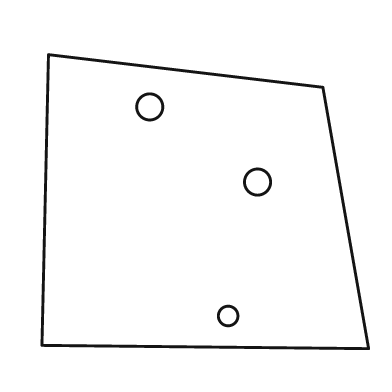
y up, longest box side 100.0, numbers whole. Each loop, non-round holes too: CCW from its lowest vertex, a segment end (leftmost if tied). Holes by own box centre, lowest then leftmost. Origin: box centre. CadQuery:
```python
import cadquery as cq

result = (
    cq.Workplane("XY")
    .moveTo(50.0, -45.0)
    .lineTo(36.0, 35.0)
    .lineTo(-48.0, 45.0)
    .lineTo(-50.0, -44.0)
    .close()
    .moveTo(7.0, -35.0)
    .circle(3.0)
    .moveTo(16.0, 6.0)
    .circle(4.0)
    .moveTo(-17.0, 29.0)
    .circle(4.0)
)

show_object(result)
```